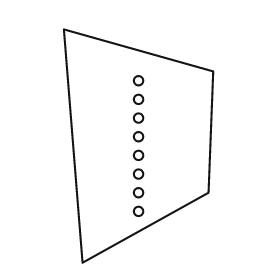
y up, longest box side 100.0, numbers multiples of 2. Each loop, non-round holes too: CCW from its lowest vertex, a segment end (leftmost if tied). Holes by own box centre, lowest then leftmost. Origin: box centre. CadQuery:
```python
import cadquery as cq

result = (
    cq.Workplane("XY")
    .moveTo(-24.0, -50.0)
    .lineTo(30.0, -20.0)
    .lineTo(32.0, 32.0)
    .lineTo(-32.0, 50.0)
    .close()
    .moveTo(0.0, -28.0)
    .circle(2.0)
    .moveTo(0.0, -20.0)
    .circle(2.0)
    .moveTo(0.0, -12.0)
    .circle(2.0)
    .moveTo(0.0, -4.0)
    .circle(2.0)
    .moveTo(0.0, 4.0)
    .circle(2.0)
    .moveTo(0.0, 12.0)
    .circle(2.0)
    .moveTo(0.0, 20.0)
    .circle(2.0)
    .moveTo(0.0, 28.0)
    .circle(2.0)
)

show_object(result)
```